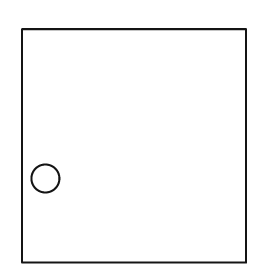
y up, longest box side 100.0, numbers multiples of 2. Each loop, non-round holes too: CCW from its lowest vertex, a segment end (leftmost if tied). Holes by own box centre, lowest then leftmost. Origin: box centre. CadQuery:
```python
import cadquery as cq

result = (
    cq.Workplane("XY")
    .moveTo(-48.0, -50.0)
    .lineTo(48.0, -50.0)
    .lineTo(48.0, 50.0)
    .lineTo(-48.0, 50.0)
    .close()
    .moveTo(-38.0, -14.0)
    .circle(6.0)
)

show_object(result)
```